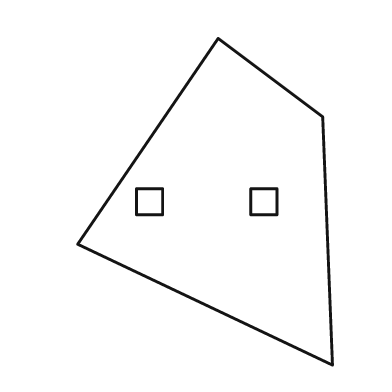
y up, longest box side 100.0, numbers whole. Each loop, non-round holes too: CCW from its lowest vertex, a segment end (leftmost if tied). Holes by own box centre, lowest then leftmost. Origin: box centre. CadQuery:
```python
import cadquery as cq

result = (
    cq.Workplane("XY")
    .moveTo(39.0, -50.0)
    .lineTo(36.0, 26.0)
    .lineTo(4.0, 50.0)
    .lineTo(-39.0, -13.0)
    .close()
    .moveTo(-21.0, -4.0)
    .lineTo(-13.0, -4.0)
    .lineTo(-13.0, 4.0)
    .lineTo(-21.0, 4.0)
    .close()
    .moveTo(14.0, -4.0)
    .lineTo(22.0, -4.0)
    .lineTo(22.0, 4.0)
    .lineTo(14.0, 4.0)
    .close()
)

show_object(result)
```